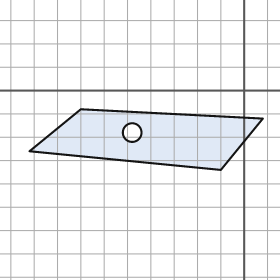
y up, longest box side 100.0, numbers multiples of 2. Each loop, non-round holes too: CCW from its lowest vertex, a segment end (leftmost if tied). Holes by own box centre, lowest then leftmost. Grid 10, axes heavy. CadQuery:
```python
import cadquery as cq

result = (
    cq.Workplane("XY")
    .moveTo(-10.0, -34.0)
    .lineTo(8.0, -12.0)
    .lineTo(-70.0, -8.0)
    .lineTo(-92.0, -26.0)
    .close()
    .moveTo(-48.0, -18.0)
    .circle(4.0)
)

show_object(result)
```